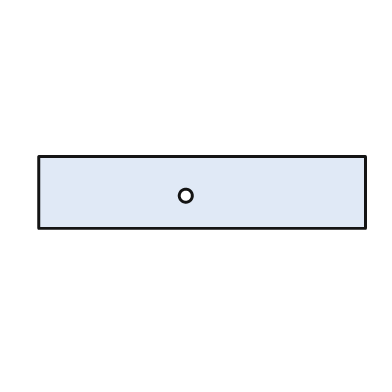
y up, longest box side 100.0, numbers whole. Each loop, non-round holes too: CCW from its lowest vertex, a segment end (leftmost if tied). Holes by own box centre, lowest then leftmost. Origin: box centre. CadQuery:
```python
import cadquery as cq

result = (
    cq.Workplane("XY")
    .moveTo(-50.0, -11.0)
    .lineTo(50.0, -11.0)
    .lineTo(50.0, 11.0)
    .lineTo(-50.0, 11.0)
    .close()
    .moveTo(-5.0, -1.0)
    .circle(2.0)
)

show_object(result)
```